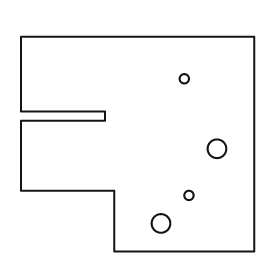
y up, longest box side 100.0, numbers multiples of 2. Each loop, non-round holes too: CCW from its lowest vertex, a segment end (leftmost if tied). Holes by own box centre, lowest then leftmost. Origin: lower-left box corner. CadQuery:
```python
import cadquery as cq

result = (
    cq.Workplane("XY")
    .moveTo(40.0, 0.0)
    .lineTo(100.0, 0.0)
    .lineTo(100.0, 92.0)
    .lineTo(0.0, 92.0)
    .lineTo(0.0, 60.0)
    .lineTo(36.0, 60.0)
    .lineTo(36.0, 56.0)
    .lineTo(0.0, 56.0)
    .lineTo(0.0, 26.0)
    .lineTo(40.0, 26.0)
    .close()
    .moveTo(60.0, 12.0)
    .circle(4.0)
    .moveTo(72.0, 24.0)
    .circle(2.0)
    .moveTo(84.0, 44.0)
    .circle(4.0)
    .moveTo(70.0, 74.0)
    .circle(2.0)
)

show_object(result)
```